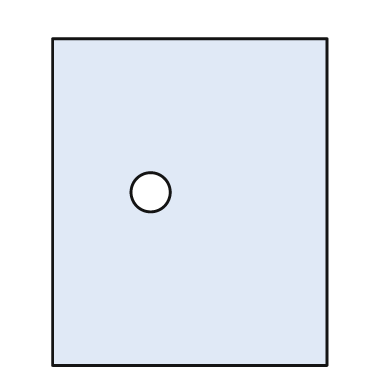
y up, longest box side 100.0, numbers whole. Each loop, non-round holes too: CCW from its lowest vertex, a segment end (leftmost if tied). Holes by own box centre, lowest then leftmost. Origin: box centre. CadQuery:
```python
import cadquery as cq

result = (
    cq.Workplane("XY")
    .moveTo(-42.0, -50.0)
    .lineTo(42.0, -50.0)
    .lineTo(42.0, 50.0)
    .lineTo(-42.0, 50.0)
    .close()
    .moveTo(-12.0, 3.0)
    .circle(6.0)
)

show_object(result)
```